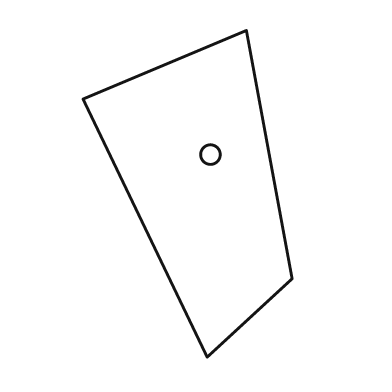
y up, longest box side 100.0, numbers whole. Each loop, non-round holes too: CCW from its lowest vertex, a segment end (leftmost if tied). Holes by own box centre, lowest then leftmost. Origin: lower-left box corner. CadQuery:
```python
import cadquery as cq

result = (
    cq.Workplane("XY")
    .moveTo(38.0, 0.0)
    .lineTo(64.0, 24.0)
    .lineTo(50.0, 100.0)
    .lineTo(0.0, 79.0)
    .close()
    .moveTo(39.0, 62.0)
    .circle(3.0)
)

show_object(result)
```